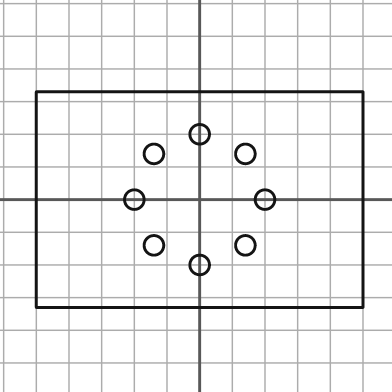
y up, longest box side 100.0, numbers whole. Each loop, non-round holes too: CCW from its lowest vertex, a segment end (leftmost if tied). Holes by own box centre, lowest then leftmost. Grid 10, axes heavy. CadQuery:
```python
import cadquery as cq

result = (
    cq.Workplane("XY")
    .moveTo(-50.0, -33.0)
    .lineTo(50.0, -33.0)
    .lineTo(50.0, 33.0)
    .lineTo(-50.0, 33.0)
    .close()
    .moveTo(0.0, -20.0)
    .circle(3.0)
    .moveTo(-14.0, -14.0)
    .circle(3.0)
    .moveTo(14.0, -14.0)
    .circle(3.0)
    .moveTo(-20.0, 0.0)
    .circle(3.0)
    .moveTo(20.0, 0.0)
    .circle(3.0)
    .moveTo(-14.0, 14.0)
    .circle(3.0)
    .moveTo(14.0, 14.0)
    .circle(3.0)
    .moveTo(0.0, 20.0)
    .circle(3.0)
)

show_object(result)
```